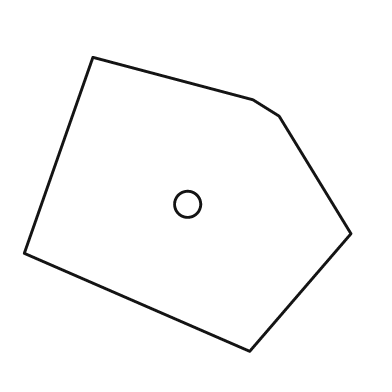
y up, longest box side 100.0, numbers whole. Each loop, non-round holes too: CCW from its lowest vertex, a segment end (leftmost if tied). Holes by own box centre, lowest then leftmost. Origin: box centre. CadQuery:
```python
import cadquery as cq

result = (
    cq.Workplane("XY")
    .moveTo(19.0, -45.0)
    .lineTo(50.0, -9.0)
    .lineTo(28.0, 27.0)
    .lineTo(20.0, 32.0)
    .lineTo(-29.0, 45.0)
    .lineTo(-50.0, -15.0)
    .close()
    .moveTo(0.0, 0.0)
    .circle(4.0)
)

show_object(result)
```